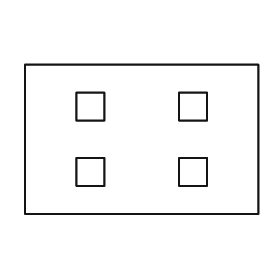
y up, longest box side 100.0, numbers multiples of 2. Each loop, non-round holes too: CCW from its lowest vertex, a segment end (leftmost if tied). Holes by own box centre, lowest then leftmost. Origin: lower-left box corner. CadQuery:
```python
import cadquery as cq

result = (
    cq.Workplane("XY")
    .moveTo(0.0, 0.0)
    .lineTo(100.0, 0.0)
    .lineTo(100.0, 64.0)
    .lineTo(0.0, 64.0)
    .close()
    .moveTo(22.0, 12.0)
    .lineTo(34.0, 12.0)
    .lineTo(34.0, 24.0)
    .lineTo(22.0, 24.0)
    .close()
    .moveTo(66.0, 12.0)
    .lineTo(78.0, 12.0)
    .lineTo(78.0, 24.0)
    .lineTo(66.0, 24.0)
    .close()
    .moveTo(22.0, 40.0)
    .lineTo(34.0, 40.0)
    .lineTo(34.0, 52.0)
    .lineTo(22.0, 52.0)
    .close()
    .moveTo(66.0, 40.0)
    .lineTo(78.0, 40.0)
    .lineTo(78.0, 52.0)
    .lineTo(66.0, 52.0)
    .close()
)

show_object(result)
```